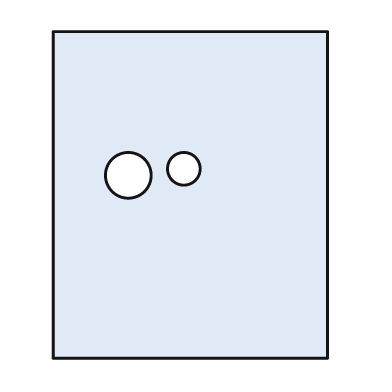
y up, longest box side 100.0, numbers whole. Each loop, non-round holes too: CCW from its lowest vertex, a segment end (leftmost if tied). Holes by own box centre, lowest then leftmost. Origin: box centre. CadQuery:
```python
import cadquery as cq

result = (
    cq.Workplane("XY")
    .moveTo(-42.0, -50.0)
    .lineTo(42.0, -50.0)
    .lineTo(42.0, 50.0)
    .lineTo(-42.0, 50.0)
    .close()
    .moveTo(-19.0, 6.0)
    .circle(7.0)
    .moveTo(-2.0, 8.0)
    .circle(5.0)
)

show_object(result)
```